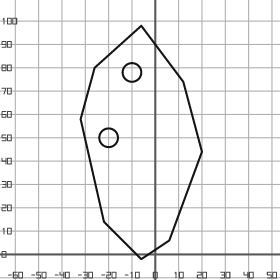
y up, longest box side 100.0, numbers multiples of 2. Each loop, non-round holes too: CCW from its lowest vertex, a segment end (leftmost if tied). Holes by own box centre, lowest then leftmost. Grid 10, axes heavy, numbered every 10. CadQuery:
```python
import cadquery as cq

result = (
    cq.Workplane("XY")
    .moveTo(-6.0, -2.0)
    .lineTo(6.0, 6.0)
    .lineTo(20.0, 44.0)
    .lineTo(12.0, 74.0)
    .lineTo(-6.0, 98.0)
    .lineTo(-26.0, 80.0)
    .lineTo(-32.0, 58.0)
    .lineTo(-22.0, 14.0)
    .close()
    .moveTo(-20.0, 50.0)
    .circle(4.0)
    .moveTo(-10.0, 78.0)
    .circle(4.0)
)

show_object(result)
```